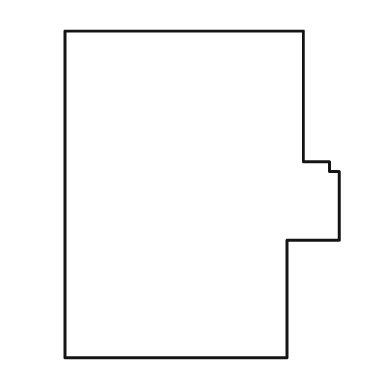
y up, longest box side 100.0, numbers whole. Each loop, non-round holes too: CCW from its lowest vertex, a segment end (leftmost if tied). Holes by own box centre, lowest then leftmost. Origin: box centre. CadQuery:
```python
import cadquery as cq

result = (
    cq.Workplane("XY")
    .moveTo(-42.0, -50.0)
    .lineTo(26.0, -50.0)
    .lineTo(26.0, -14.0)
    .lineTo(42.0, -14.0)
    .lineTo(42.0, 7.0)
    .lineTo(39.0, 7.0)
    .lineTo(39.0, 10.0)
    .lineTo(31.0, 10.0)
    .lineTo(31.0, 50.0)
    .lineTo(-42.0, 50.0)
    .close()
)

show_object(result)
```